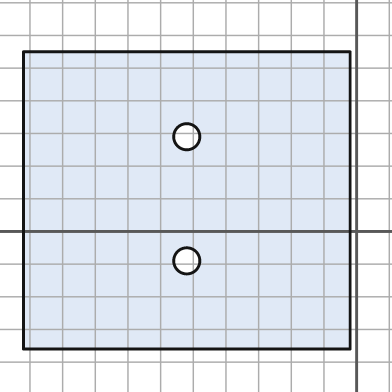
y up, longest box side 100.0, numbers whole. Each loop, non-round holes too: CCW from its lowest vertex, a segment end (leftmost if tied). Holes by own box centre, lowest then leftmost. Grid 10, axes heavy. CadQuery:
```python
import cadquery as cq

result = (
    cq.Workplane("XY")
    .moveTo(-102.0, -36.0)
    .lineTo(-2.0, -36.0)
    .lineTo(-2.0, 55.0)
    .lineTo(-102.0, 55.0)
    .close()
    .moveTo(-52.0, -9.0)
    .circle(4.0)
    .moveTo(-52.0, 29.0)
    .circle(4.0)
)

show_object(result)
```